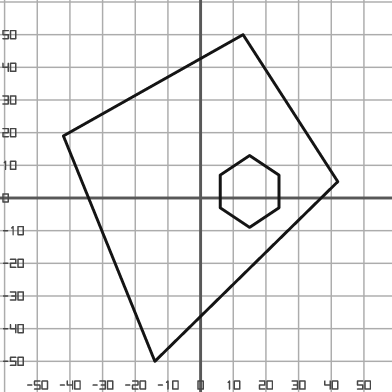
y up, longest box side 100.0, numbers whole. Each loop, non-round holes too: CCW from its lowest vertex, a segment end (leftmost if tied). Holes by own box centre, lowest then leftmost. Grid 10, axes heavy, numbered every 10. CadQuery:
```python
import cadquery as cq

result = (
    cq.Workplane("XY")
    .moveTo(-14.0, -50.0)
    .lineTo(42.0, 5.0)
    .lineTo(13.0, 50.0)
    .lineTo(-42.0, 19.0)
    .close()
    .moveTo(15.0, -9.0)
    .lineTo(24.0, -3.0)
    .lineTo(24.0, 7.0)
    .lineTo(15.0, 13.0)
    .lineTo(6.0, 7.0)
    .lineTo(6.0, -3.0)
    .close()
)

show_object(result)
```